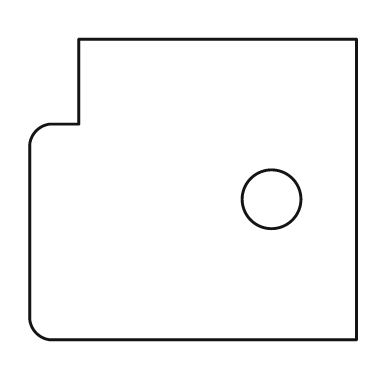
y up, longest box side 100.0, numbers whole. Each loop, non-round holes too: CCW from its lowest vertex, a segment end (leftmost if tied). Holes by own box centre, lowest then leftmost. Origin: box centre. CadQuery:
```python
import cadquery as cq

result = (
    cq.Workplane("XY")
    .moveTo(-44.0, -46.0)
    .lineTo(50.0, -46.0)
    .lineTo(50.0, 46.0)
    .lineTo(-35.0, 46.0)
    .lineTo(-35.0, 20.0)
    .lineTo(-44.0, 20.0)
    .threePointArc((-48.0, 18.0), (-50.0, 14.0))
    .lineTo(-50.0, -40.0)
    .threePointArc((-48.0, -44.0), (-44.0, -46.0))
    .close()
    .moveTo(24.0, -3.0)
    .circle(9.0)
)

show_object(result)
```